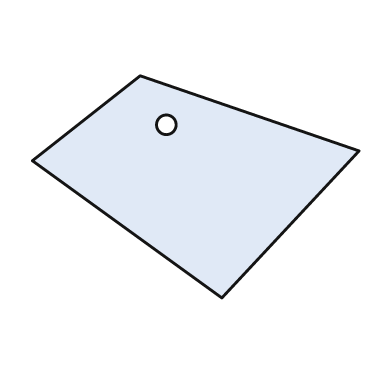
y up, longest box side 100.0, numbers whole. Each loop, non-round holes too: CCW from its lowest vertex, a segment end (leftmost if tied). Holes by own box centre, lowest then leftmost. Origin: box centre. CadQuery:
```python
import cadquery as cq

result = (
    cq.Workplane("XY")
    .moveTo(8.0, -34.0)
    .lineTo(50.0, 11.0)
    .lineTo(-17.0, 34.0)
    .lineTo(-50.0, 8.0)
    .close()
    .moveTo(-9.0, 19.0)
    .circle(3.0)
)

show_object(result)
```